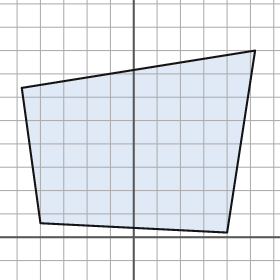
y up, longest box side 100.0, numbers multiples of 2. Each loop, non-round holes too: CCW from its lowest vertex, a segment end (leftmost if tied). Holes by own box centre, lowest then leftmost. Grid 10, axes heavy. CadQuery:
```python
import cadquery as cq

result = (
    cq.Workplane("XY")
    .moveTo(40.0, 2.0)
    .lineTo(52.0, 80.0)
    .lineTo(-48.0, 64.0)
    .lineTo(-40.0, 6.0)
    .close()
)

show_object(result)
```